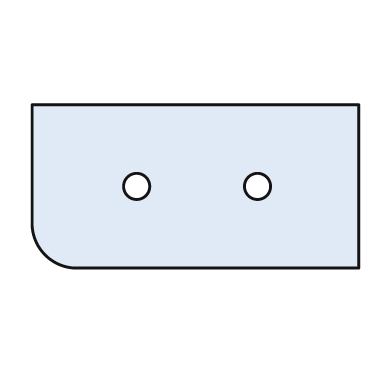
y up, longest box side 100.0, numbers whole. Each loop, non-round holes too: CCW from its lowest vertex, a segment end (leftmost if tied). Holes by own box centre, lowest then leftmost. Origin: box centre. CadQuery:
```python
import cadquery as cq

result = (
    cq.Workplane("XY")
    .moveTo(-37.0, -25.0)
    .lineTo(50.0, -25.0)
    .lineTo(50.0, 25.0)
    .lineTo(-50.0, 25.0)
    .lineTo(-50.0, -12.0)
    .threePointArc((-46.0, -21.0), (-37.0, -25.0))
    .close()
    .moveTo(-18.0, 0.0)
    .circle(4.0)
    .moveTo(19.0, 0.0)
    .circle(4.0)
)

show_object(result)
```